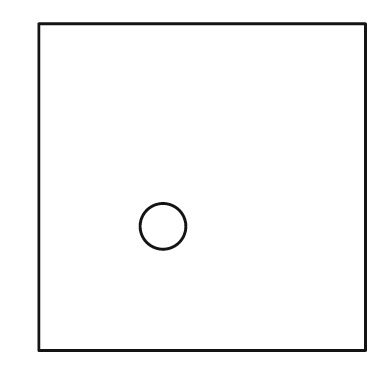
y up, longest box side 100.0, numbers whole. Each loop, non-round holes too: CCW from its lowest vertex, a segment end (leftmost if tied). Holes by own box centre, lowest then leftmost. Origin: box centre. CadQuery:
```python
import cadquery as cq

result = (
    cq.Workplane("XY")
    .moveTo(-50.0, -50.0)
    .lineTo(50.0, -50.0)
    .lineTo(50.0, 50.0)
    .lineTo(-50.0, 50.0)
    .close()
    .moveTo(-12.0, -12.0)
    .circle(7.0)
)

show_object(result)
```